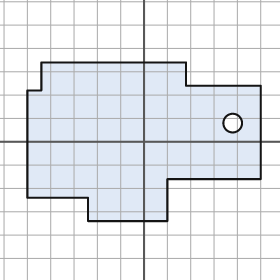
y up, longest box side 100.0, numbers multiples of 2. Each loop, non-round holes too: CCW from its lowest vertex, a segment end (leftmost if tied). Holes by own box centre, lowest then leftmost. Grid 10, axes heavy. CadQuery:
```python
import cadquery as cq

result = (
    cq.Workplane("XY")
    .moveTo(-24.0, -34.0)
    .lineTo(10.0, -34.0)
    .lineTo(10.0, -16.0)
    .lineTo(50.0, -16.0)
    .lineTo(50.0, 24.0)
    .lineTo(18.0, 24.0)
    .lineTo(18.0, 34.0)
    .lineTo(-44.0, 34.0)
    .lineTo(-44.0, 22.0)
    .lineTo(-50.0, 22.0)
    .lineTo(-50.0, -24.0)
    .lineTo(-24.0, -24.0)
    .close()
    .moveTo(38.0, 8.0)
    .circle(4.0)
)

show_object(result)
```